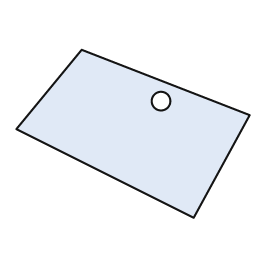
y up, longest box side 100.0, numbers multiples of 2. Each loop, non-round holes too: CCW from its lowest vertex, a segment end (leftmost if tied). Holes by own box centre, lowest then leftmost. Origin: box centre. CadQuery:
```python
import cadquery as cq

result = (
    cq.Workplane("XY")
    .moveTo(26.0, -36.0)
    .lineTo(50.0, 8.0)
    .lineTo(-22.0, 36.0)
    .lineTo(-50.0, 2.0)
    .close()
    .moveTo(12.0, 14.0)
    .circle(4.0)
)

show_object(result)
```